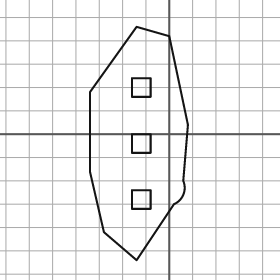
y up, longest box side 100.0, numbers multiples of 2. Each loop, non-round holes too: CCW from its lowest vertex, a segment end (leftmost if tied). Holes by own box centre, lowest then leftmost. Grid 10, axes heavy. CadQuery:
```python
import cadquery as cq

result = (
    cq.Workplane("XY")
    .moveTo(-14.0, -54.0)
    .lineTo(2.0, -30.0)
    .threePointArc((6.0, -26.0), (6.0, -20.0))
    .lineTo(8.0, 4.0)
    .lineTo(0.0, 42.0)
    .lineTo(-14.0, 46.0)
    .lineTo(-34.0, 18.0)
    .lineTo(-34.0, -16.0)
    .lineTo(-28.0, -42.0)
    .close()
    .moveTo(-16.0, -32.0)
    .lineTo(-8.0, -32.0)
    .lineTo(-8.0, -24.0)
    .lineTo(-16.0, -24.0)
    .close()
    .moveTo(-16.0, -8.0)
    .lineTo(-8.0, -8.0)
    .lineTo(-8.0, 0.0)
    .lineTo(-16.0, 0.0)
    .close()
    .moveTo(-16.0, 16.0)
    .lineTo(-8.0, 16.0)
    .lineTo(-8.0, 24.0)
    .lineTo(-16.0, 24.0)
    .close()
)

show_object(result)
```